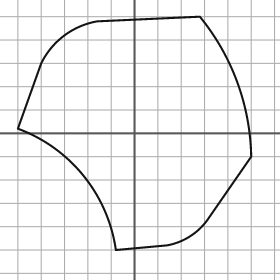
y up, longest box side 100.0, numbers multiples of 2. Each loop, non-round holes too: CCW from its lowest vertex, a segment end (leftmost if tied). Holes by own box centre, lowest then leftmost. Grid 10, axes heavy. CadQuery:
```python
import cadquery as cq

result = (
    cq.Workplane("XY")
    .moveTo(-8.0, -50.0)
    .lineTo(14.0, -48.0)
    .threePointArc((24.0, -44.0), (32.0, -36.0))
    .lineTo(50.0, -10.0)
    .threePointArc((44.0, 22.0), (28.0, 50.0))
    .lineTo(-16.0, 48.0)
    .threePointArc((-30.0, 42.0), (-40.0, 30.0))
    .lineTo(-50.0, 2.0)
    .threePointArc((-22.0, -18.0), (-8.0, -50.0))
    .close()
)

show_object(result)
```